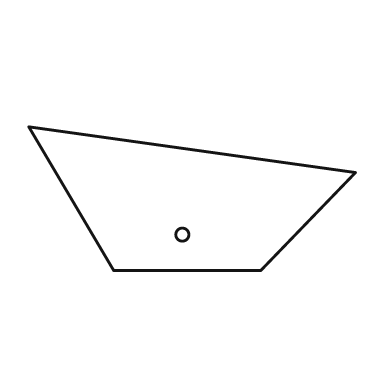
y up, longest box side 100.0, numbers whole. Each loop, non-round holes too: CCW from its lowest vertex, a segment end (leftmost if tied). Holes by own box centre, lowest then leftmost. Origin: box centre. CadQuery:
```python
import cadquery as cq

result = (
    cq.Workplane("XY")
    .moveTo(-24.0, -22.0)
    .lineTo(21.0, -22.0)
    .lineTo(50.0, 8.0)
    .lineTo(-50.0, 22.0)
    .close()
    .moveTo(-3.0, -11.0)
    .circle(2.0)
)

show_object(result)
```